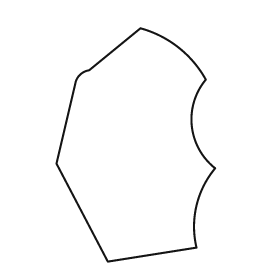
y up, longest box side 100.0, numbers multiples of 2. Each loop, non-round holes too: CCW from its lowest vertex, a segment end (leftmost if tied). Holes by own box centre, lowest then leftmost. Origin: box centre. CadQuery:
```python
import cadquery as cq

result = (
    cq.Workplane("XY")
    .moveTo(-12.0, -50.0)
    .lineTo(26.0, -44.0)
    .threePointArc((26.0, -26.0), (34.0, -10.0))
    .threePointArc((24.0, 8.0), (30.0, 28.0))
    .threePointArc((18.0, 42.0), (2.0, 50.0))
    .lineTo(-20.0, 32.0)
    .threePointArc((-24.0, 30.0), (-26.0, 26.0))
    .lineTo(-34.0, -8.0)
    .close()
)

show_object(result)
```